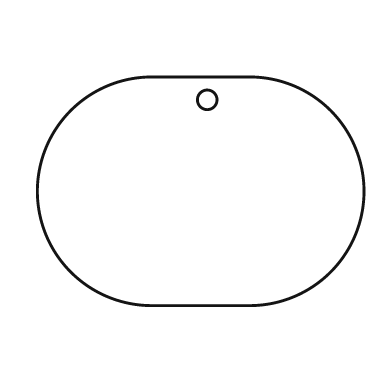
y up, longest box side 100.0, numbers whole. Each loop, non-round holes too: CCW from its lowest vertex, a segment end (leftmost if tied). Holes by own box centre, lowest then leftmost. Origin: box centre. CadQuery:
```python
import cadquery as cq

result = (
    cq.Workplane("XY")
    .moveTo(-15.0, -35.0)
    .lineTo(15.0, -35.0)
    .threePointArc((50.0, 0.0), (15.0, 35.0))
    .lineTo(-15.0, 35.0)
    .threePointArc((-50.0, 0.0), (-15.0, -35.0))
    .close()
    .moveTo(2.0, 28.0)
    .circle(3.0)
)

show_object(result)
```